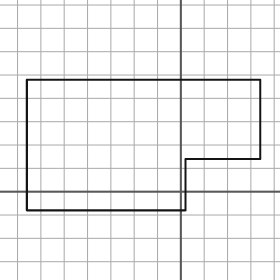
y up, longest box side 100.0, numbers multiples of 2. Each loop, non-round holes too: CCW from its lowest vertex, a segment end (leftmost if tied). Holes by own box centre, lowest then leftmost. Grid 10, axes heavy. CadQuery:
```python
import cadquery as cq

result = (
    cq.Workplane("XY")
    .moveTo(-66.0, -8.0)
    .lineTo(2.0, -8.0)
    .lineTo(2.0, 14.0)
    .lineTo(34.0, 14.0)
    .lineTo(34.0, 48.0)
    .lineTo(-66.0, 48.0)
    .close()
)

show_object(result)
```